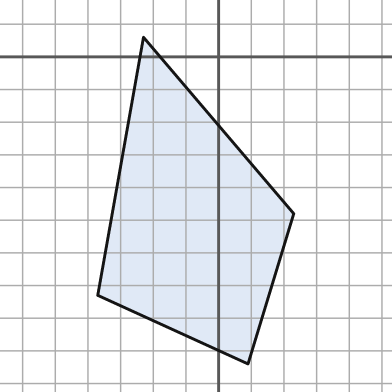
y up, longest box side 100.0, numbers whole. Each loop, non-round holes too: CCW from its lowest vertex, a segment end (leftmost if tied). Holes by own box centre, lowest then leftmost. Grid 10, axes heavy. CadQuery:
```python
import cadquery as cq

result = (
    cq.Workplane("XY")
    .moveTo(9.0, -94.0)
    .lineTo(23.0, -48.0)
    .lineTo(-23.0, 6.0)
    .lineTo(-37.0, -73.0)
    .close()
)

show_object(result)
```